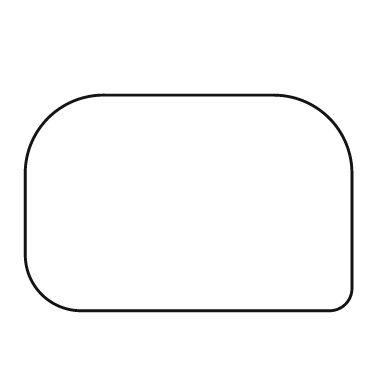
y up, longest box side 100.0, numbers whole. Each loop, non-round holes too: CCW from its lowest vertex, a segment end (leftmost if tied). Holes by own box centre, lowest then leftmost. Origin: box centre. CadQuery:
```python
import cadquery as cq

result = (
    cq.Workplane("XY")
    .moveTo(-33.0, -33.0)
    .lineTo(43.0, -33.0)
    .threePointArc((48.0, -31.0), (50.0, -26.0))
    .lineTo(50.0, 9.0)
    .threePointArc((43.0, 26.0), (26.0, 33.0))
    .lineTo(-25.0, 33.0)
    .threePointArc((-43.0, 26.0), (-50.0, 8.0))
    .lineTo(-50.0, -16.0)
    .threePointArc((-45.0, -28.0), (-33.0, -33.0))
    .close()
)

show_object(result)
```